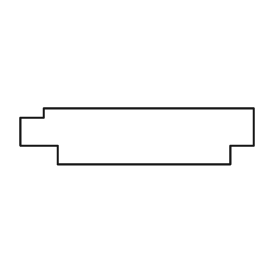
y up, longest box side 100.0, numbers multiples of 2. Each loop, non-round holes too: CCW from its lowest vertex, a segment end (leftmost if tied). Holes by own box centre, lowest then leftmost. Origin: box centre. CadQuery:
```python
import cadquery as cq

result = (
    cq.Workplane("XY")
    .moveTo(-34.0, -12.0)
    .lineTo(40.0, -12.0)
    .lineTo(40.0, -4.0)
    .lineTo(50.0, -4.0)
    .lineTo(50.0, 12.0)
    .lineTo(-40.0, 12.0)
    .lineTo(-40.0, 8.0)
    .lineTo(-50.0, 8.0)
    .lineTo(-50.0, -4.0)
    .lineTo(-34.0, -4.0)
    .close()
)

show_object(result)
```